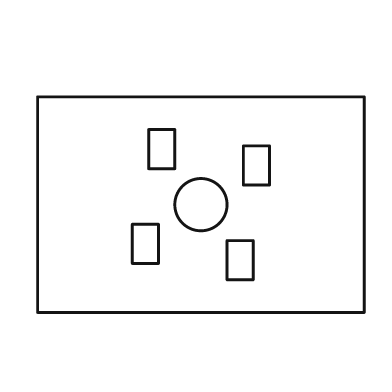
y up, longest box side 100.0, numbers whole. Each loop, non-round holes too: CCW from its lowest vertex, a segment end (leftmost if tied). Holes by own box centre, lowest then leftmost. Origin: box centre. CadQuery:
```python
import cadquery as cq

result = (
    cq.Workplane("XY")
    .moveTo(-50.0, -33.0)
    .lineTo(50.0, -33.0)
    .lineTo(50.0, 33.0)
    .lineTo(-50.0, 33.0)
    .close()
    .moveTo(8.0, -23.0)
    .lineTo(16.0, -23.0)
    .lineTo(16.0, -11.0)
    .lineTo(8.0, -11.0)
    .close()
    .moveTo(-21.0, -18.0)
    .lineTo(-13.0, -18.0)
    .lineTo(-13.0, -6.0)
    .lineTo(-21.0, -6.0)
    .close()
    .moveTo(0.0, 0.0)
    .circle(8.0)
    .moveTo(13.0, 6.0)
    .lineTo(21.0, 6.0)
    .lineTo(21.0, 18.0)
    .lineTo(13.0, 18.0)
    .close()
    .moveTo(-16.0, 11.0)
    .lineTo(-8.0, 11.0)
    .lineTo(-8.0, 23.0)
    .lineTo(-16.0, 23.0)
    .close()
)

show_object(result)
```